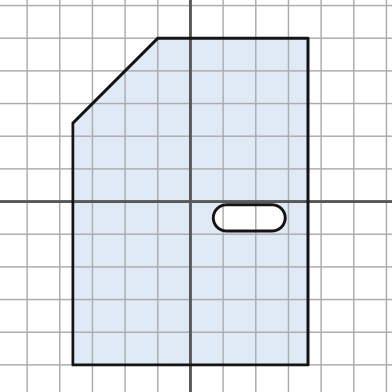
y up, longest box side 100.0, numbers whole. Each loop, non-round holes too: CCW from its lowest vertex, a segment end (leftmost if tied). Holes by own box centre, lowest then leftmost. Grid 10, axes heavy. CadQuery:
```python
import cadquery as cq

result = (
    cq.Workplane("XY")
    .moveTo(-36.0, -50.0)
    .lineTo(36.0, -50.0)
    .lineTo(36.0, 50.0)
    .lineTo(-10.0, 50.0)
    .lineTo(-36.0, 24.0)
    .close()
    .moveTo(11.0, -9.0)
    .lineTo(25.0, -9.0)
    .threePointArc((29.0, -5.0), (25.0, -1.0))
    .lineTo(11.0, -1.0)
    .threePointArc((7.0, -5.0), (11.0, -9.0))
    .close()
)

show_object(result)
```